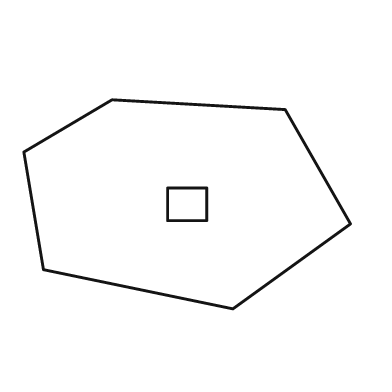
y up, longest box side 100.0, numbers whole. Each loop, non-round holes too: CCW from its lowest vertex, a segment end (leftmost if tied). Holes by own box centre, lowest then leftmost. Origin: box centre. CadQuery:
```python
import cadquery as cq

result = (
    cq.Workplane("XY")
    .moveTo(14.0, -32.0)
    .lineTo(50.0, -6.0)
    .lineTo(30.0, 29.0)
    .lineTo(-23.0, 32.0)
    .lineTo(-50.0, 16.0)
    .lineTo(-44.0, -20.0)
    .close()
    .moveTo(-6.0, -5.0)
    .lineTo(6.0, -5.0)
    .lineTo(6.0, 5.0)
    .lineTo(-6.0, 5.0)
    .close()
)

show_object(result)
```